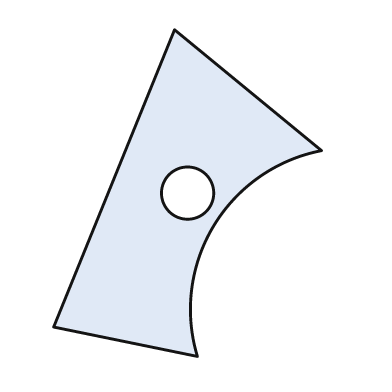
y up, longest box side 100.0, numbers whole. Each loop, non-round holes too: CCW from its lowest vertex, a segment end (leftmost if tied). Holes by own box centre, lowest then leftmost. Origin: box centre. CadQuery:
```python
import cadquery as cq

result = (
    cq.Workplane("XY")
    .moveTo(3.0, -50.0)
    .threePointArc((8.0, -10.0), (41.0, 13.0))
    .lineTo(-4.0, 50.0)
    .lineTo(-41.0, -41.0)
    .close()
    .moveTo(0.0, 0.0)
    .circle(8.0)
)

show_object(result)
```